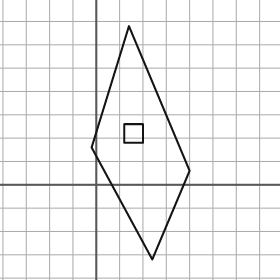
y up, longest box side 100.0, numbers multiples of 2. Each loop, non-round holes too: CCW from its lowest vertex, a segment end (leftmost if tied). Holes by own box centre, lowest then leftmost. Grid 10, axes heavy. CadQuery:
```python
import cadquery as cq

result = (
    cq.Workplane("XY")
    .moveTo(24.0, -32.0)
    .lineTo(40.0, 6.0)
    .lineTo(14.0, 68.0)
    .lineTo(-2.0, 16.0)
    .close()
    .moveTo(12.0, 18.0)
    .lineTo(20.0, 18.0)
    .lineTo(20.0, 26.0)
    .lineTo(12.0, 26.0)
    .close()
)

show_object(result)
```